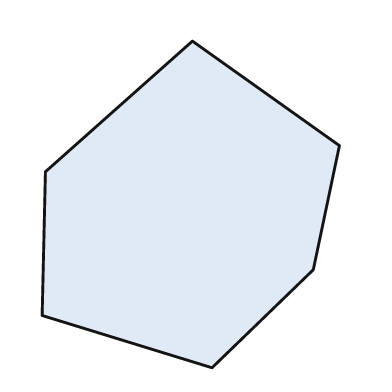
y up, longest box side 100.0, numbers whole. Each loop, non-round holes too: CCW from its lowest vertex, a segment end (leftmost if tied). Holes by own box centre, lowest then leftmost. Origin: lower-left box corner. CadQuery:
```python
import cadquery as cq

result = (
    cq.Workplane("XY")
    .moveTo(52.0, 0.0)
    .lineTo(83.0, 30.0)
    .lineTo(91.0, 68.0)
    .lineTo(46.0, 100.0)
    .lineTo(1.0, 60.0)
    .lineTo(0.0, 16.0)
    .close()
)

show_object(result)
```